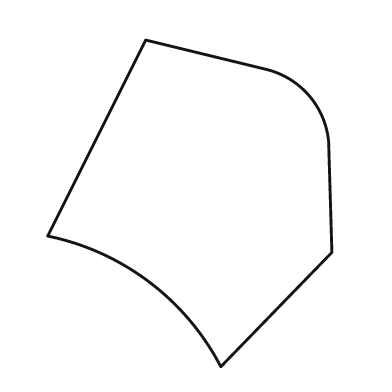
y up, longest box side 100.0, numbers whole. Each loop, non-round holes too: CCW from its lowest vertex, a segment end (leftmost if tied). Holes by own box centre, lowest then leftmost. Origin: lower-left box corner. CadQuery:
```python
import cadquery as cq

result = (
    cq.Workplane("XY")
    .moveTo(53.0, 0.0)
    .lineTo(87.0, 35.0)
    .lineTo(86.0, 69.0)
    .threePointArc((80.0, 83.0), (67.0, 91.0))
    .lineTo(30.0, 100.0)
    .lineTo(0.0, 40.0)
    .threePointArc((31.0, 26.0), (53.0, 0.0))
    .close()
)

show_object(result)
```